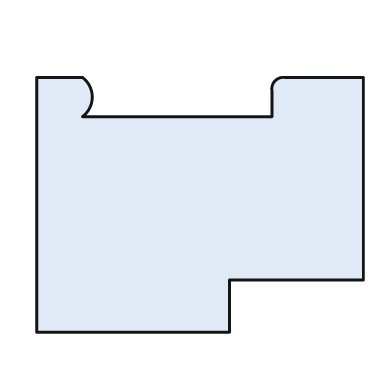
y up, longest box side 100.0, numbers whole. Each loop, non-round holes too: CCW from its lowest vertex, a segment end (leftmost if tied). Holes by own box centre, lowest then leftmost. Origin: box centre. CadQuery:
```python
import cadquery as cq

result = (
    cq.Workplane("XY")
    .moveTo(-50.0, -39.0)
    .lineTo(9.0, -39.0)
    .lineTo(9.0, -23.0)
    .lineTo(50.0, -23.0)
    .lineTo(50.0, 39.0)
    .lineTo(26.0, 39.0)
    .threePointArc((23.0, 38.0), (22.0, 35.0))
    .lineTo(22.0, 27.0)
    .lineTo(-36.0, 27.0)
    .threePointArc((-33.0, 33.0), (-36.0, 39.0))
    .lineTo(-50.0, 39.0)
    .close()
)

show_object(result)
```